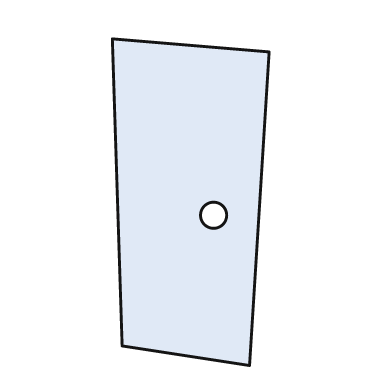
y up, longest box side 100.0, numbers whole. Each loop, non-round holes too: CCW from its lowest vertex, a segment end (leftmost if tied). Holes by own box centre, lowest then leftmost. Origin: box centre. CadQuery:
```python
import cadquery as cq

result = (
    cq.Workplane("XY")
    .moveTo(18.0, -50.0)
    .lineTo(24.0, 46.0)
    .lineTo(-24.0, 50.0)
    .lineTo(-21.0, -44.0)
    .close()
    .moveTo(7.0, -4.0)
    .circle(4.0)
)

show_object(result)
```